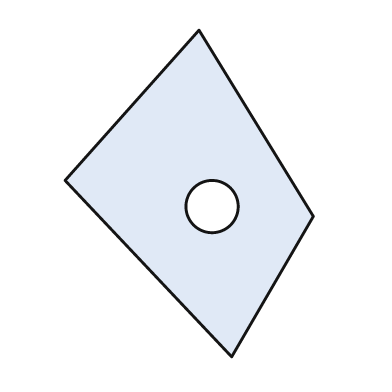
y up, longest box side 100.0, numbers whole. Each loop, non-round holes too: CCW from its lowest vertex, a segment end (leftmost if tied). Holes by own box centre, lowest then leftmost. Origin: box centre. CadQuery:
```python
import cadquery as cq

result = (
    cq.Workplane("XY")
    .moveTo(13.0, -50.0)
    .lineTo(38.0, -7.0)
    .lineTo(3.0, 50.0)
    .lineTo(-38.0, 4.0)
    .close()
    .moveTo(7.0, -4.0)
    .circle(8.0)
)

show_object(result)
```